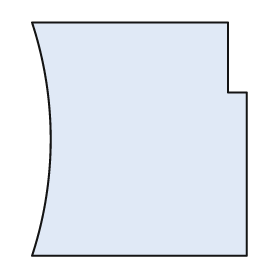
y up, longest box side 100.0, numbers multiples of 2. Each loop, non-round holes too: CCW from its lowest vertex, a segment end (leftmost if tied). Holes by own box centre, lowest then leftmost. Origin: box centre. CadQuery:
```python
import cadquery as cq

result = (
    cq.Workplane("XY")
    .moveTo(-46.0, -50.0)
    .lineTo(46.0, -50.0)
    .lineTo(46.0, 20.0)
    .lineTo(38.0, 20.0)
    .lineTo(38.0, 50.0)
    .lineTo(-46.0, 50.0)
    .threePointArc((-38.0, 0.0), (-46.0, -50.0))
    .close()
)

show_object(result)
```